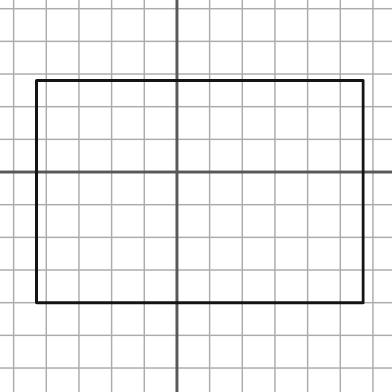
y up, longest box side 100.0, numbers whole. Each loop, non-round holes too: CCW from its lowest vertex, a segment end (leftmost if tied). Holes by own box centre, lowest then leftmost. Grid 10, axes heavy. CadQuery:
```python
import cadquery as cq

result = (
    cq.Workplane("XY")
    .moveTo(-43.0, -40.0)
    .lineTo(57.0, -40.0)
    .lineTo(57.0, 28.0)
    .lineTo(-43.0, 28.0)
    .close()
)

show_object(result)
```